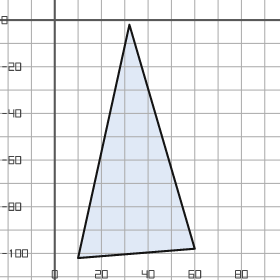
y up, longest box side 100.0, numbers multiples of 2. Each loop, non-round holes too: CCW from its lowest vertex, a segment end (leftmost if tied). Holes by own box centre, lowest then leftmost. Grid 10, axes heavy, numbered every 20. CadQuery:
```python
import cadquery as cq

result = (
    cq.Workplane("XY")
    .moveTo(10.0, -102.0)
    .lineTo(60.0, -98.0)
    .lineTo(32.0, -2.0)
    .close()
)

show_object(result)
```